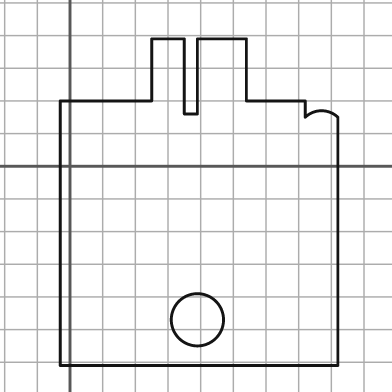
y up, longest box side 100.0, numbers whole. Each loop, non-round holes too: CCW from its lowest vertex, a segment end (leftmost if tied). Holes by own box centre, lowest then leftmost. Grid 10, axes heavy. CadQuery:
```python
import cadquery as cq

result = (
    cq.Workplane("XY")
    .moveTo(-3.0, -61.0)
    .lineTo(82.0, -61.0)
    .lineTo(82.0, 15.0)
    .threePointArc((77.0, 17.0), (72.0, 15.0))
    .lineTo(72.0, 20.0)
    .lineTo(54.0, 20.0)
    .lineTo(54.0, 39.0)
    .lineTo(39.0, 39.0)
    .lineTo(39.0, 16.0)
    .lineTo(35.0, 16.0)
    .lineTo(35.0, 39.0)
    .lineTo(25.0, 39.0)
    .lineTo(25.0, 20.0)
    .lineTo(-3.0, 20.0)
    .close()
    .moveTo(39.0, -47.0)
    .circle(8.0)
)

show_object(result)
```